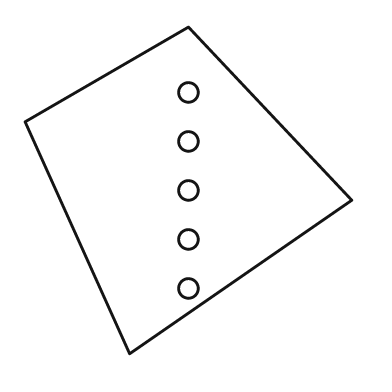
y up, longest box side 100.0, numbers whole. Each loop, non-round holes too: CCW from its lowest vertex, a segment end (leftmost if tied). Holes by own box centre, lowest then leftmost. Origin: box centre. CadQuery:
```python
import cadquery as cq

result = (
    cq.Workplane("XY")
    .moveTo(-18.0, -50.0)
    .lineTo(50.0, -3.0)
    .lineTo(0.0, 50.0)
    .lineTo(-50.0, 21.0)
    .close()
    .moveTo(0.0, -30.0)
    .circle(3.0)
    .moveTo(0.0, -15.0)
    .circle(3.0)
    .moveTo(0.0, 0.0)
    .circle(3.0)
    .moveTo(0.0, 15.0)
    .circle(3.0)
    .moveTo(0.0, 30.0)
    .circle(3.0)
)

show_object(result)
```